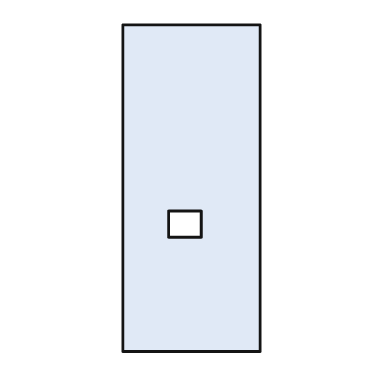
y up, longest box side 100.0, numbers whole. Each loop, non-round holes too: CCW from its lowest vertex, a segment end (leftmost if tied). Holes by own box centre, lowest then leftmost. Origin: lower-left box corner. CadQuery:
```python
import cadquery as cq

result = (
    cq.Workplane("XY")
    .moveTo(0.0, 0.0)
    .lineTo(42.0, 0.0)
    .lineTo(42.0, 100.0)
    .lineTo(0.0, 100.0)
    .close()
    .moveTo(14.0, 35.0)
    .lineTo(24.0, 35.0)
    .lineTo(24.0, 43.0)
    .lineTo(14.0, 43.0)
    .close()
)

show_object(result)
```